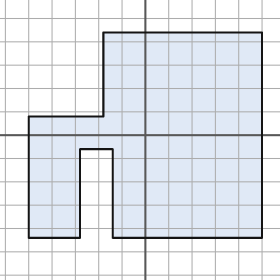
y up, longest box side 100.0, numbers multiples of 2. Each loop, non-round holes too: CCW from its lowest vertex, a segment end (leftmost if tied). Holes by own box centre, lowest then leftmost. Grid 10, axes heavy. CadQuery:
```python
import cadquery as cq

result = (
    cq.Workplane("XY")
    .moveTo(-50.0, -44.0)
    .lineTo(-28.0, -44.0)
    .lineTo(-28.0, -6.0)
    .lineTo(-14.0, -6.0)
    .lineTo(-14.0, -44.0)
    .lineTo(50.0, -44.0)
    .lineTo(50.0, 44.0)
    .lineTo(-18.0, 44.0)
    .lineTo(-18.0, 8.0)
    .lineTo(-50.0, 8.0)
    .close()
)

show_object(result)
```